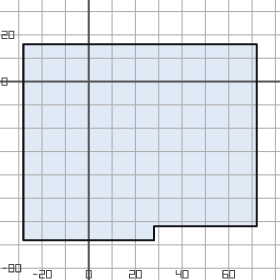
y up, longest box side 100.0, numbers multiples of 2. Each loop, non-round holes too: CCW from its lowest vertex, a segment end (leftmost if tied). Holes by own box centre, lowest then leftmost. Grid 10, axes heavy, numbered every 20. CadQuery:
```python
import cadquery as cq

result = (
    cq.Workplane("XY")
    .moveTo(-28.0, -68.0)
    .lineTo(28.0, -68.0)
    .lineTo(28.0, -62.0)
    .lineTo(72.0, -62.0)
    .lineTo(72.0, 16.0)
    .lineTo(-28.0, 16.0)
    .close()
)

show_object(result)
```